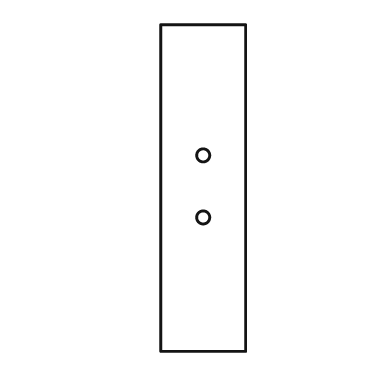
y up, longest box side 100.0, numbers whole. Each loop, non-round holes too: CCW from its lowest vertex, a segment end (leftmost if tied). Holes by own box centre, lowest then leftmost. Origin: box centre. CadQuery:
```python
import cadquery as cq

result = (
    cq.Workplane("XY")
    .moveTo(-13.0, -50.0)
    .lineTo(13.0, -50.0)
    .lineTo(13.0, 50.0)
    .lineTo(-13.0, 50.0)
    .close()
    .moveTo(0.0, -9.0)
    .circle(2.0)
    .moveTo(0.0, 10.0)
    .circle(2.0)
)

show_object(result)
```